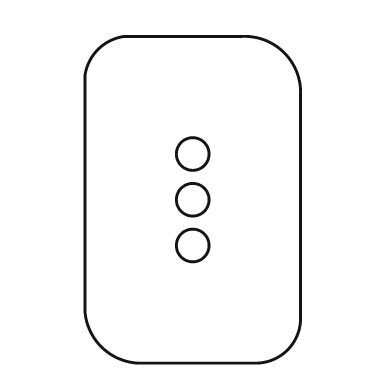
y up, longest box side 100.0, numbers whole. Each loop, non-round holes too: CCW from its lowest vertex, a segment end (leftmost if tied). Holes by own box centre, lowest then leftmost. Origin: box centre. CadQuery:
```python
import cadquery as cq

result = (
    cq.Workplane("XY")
    .moveTo(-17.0, -50.0)
    .lineTo(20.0, -50.0)
    .threePointArc((29.0, -46.0), (33.0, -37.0))
    .lineTo(33.0, 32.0)
    .threePointArc((28.0, 45.0), (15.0, 50.0))
    .lineTo(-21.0, 50.0)
    .threePointArc((-29.0, 46.0), (-33.0, 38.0))
    .lineTo(-33.0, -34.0)
    .threePointArc((-28.0, -45.0), (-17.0, -50.0))
    .close()
    .moveTo(0.0, -14.0)
    .circle(5.0)
    .moveTo(0.0, 0.0)
    .circle(5.0)
    .moveTo(0.0, 14.0)
    .circle(5.0)
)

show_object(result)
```